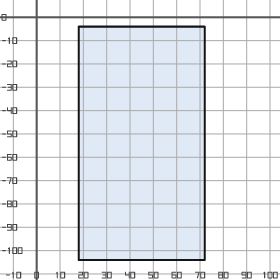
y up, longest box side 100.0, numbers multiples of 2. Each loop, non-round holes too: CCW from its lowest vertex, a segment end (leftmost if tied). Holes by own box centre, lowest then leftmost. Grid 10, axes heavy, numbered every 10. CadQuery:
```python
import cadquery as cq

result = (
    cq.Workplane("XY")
    .moveTo(18.0, -104.0)
    .lineTo(72.0, -104.0)
    .lineTo(72.0, -4.0)
    .lineTo(18.0, -4.0)
    .close()
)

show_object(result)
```